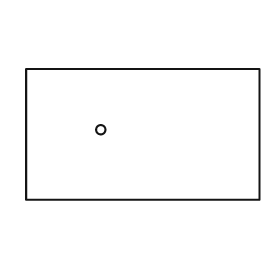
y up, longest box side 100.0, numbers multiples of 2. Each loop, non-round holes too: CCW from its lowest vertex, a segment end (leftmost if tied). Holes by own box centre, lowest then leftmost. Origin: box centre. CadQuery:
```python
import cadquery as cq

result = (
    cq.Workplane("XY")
    .moveTo(-50.0, -28.0)
    .lineTo(50.0, -28.0)
    .lineTo(50.0, 28.0)
    .lineTo(-50.0, 28.0)
    .close()
    .moveTo(-18.0, 2.0)
    .circle(2.0)
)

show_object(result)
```